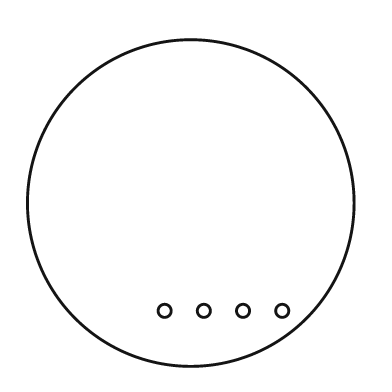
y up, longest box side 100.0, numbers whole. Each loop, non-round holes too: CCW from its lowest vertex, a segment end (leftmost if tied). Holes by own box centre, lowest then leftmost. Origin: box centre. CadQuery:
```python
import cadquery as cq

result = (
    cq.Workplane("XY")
    .moveTo(0.0, 0.0)
    .circle(50.0)
    .moveTo(-8.0, -33.0)
    .circle(2.0)
    .moveTo(4.0, -33.0)
    .circle(2.0)
    .moveTo(16.0, -33.0)
    .circle(2.0)
    .moveTo(28.0, -33.0)
    .circle(2.0)
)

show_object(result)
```